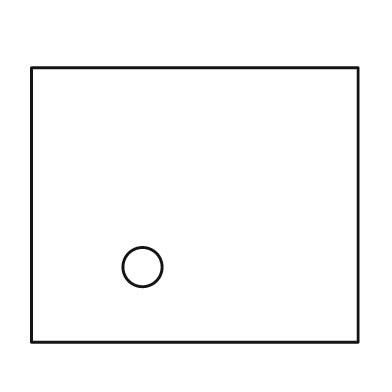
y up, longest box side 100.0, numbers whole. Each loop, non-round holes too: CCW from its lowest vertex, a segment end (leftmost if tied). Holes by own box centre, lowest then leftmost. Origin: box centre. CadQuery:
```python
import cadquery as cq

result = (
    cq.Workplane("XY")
    .moveTo(-50.0, -42.0)
    .lineTo(50.0, -42.0)
    .lineTo(50.0, 42.0)
    .lineTo(-50.0, 42.0)
    .close()
    .moveTo(-16.0, -19.0)
    .circle(6.0)
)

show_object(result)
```